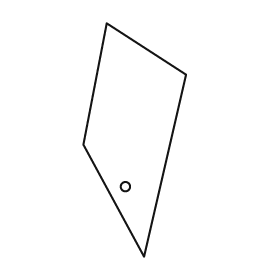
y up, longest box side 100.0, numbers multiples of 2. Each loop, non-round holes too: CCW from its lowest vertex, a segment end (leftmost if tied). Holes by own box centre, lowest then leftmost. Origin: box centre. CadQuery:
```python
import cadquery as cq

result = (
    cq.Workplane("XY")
    .moveTo(4.0, -50.0)
    .lineTo(22.0, 28.0)
    .lineTo(-12.0, 50.0)
    .lineTo(-22.0, -2.0)
    .close()
    .moveTo(-4.0, -20.0)
    .circle(2.0)
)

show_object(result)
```